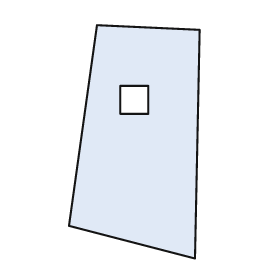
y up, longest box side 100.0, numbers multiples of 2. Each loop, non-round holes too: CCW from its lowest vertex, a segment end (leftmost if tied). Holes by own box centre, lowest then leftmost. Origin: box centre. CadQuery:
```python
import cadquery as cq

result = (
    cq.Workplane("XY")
    .moveTo(26.0, -50.0)
    .lineTo(28.0, 48.0)
    .lineTo(-16.0, 50.0)
    .lineTo(-28.0, -36.0)
    .close()
    .moveTo(-6.0, 12.0)
    .lineTo(6.0, 12.0)
    .lineTo(6.0, 24.0)
    .lineTo(-6.0, 24.0)
    .close()
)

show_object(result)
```